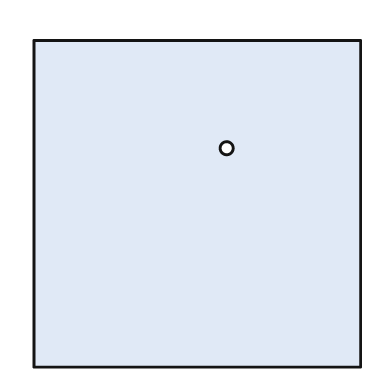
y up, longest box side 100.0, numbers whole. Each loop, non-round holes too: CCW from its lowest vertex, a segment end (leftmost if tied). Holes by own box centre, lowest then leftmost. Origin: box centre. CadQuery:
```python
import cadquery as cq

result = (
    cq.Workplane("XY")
    .moveTo(-50.0, -50.0)
    .lineTo(50.0, -50.0)
    .lineTo(50.0, 50.0)
    .lineTo(-50.0, 50.0)
    .close()
    .moveTo(9.0, 17.0)
    .circle(2.0)
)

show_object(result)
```